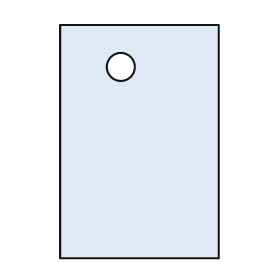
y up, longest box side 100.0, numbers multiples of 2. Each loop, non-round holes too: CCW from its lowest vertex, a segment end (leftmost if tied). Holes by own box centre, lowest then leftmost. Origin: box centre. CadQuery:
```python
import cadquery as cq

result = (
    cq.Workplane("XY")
    .moveTo(-34.0, -50.0)
    .lineTo(34.0, -50.0)
    .lineTo(34.0, 50.0)
    .lineTo(-34.0, 50.0)
    .close()
    .moveTo(-8.0, 32.0)
    .circle(6.0)
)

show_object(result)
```